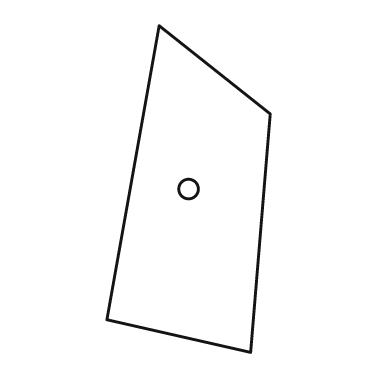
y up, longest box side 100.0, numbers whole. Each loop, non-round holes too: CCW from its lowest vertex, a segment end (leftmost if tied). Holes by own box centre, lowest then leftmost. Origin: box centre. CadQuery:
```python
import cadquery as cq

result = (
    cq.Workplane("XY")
    .moveTo(19.0, -50.0)
    .lineTo(25.0, 23.0)
    .lineTo(-9.0, 50.0)
    .lineTo(-25.0, -40.0)
    .close()
    .moveTo(0.0, 0.0)
    .circle(3.0)
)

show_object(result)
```